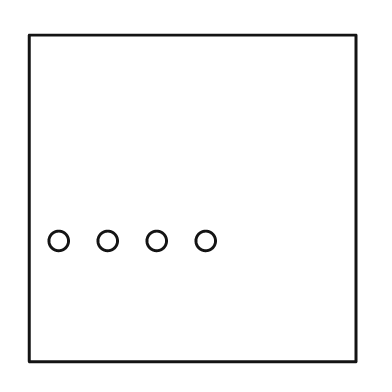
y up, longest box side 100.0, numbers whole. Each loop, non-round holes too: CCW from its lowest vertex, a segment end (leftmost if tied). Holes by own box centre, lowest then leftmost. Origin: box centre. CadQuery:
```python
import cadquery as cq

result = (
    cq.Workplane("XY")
    .moveTo(-50.0, -50.0)
    .lineTo(50.0, -50.0)
    .lineTo(50.0, 50.0)
    .lineTo(-50.0, 50.0)
    .close()
    .moveTo(-41.0, -13.0)
    .circle(3.0)
    .moveTo(-26.0, -13.0)
    .circle(3.0)
    .moveTo(-11.0, -13.0)
    .circle(3.0)
    .moveTo(4.0, -13.0)
    .circle(3.0)
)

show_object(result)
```